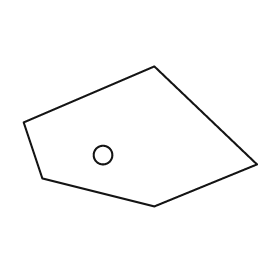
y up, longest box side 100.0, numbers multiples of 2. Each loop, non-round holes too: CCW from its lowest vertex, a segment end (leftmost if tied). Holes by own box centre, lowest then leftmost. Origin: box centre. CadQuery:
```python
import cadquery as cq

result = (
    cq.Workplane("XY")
    .moveTo(6.0, -30.0)
    .lineTo(50.0, -12.0)
    .lineTo(6.0, 30.0)
    .lineTo(-50.0, 6.0)
    .lineTo(-42.0, -18.0)
    .close()
    .moveTo(-16.0, -8.0)
    .circle(4.0)
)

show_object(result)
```